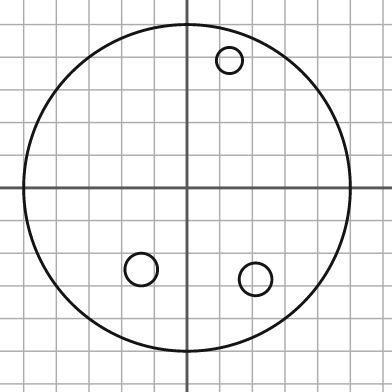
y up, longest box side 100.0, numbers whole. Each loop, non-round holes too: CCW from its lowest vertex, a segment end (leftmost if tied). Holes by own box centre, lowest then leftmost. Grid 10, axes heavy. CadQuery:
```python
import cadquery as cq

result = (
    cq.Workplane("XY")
    .moveTo(0.0, 0.0)
    .circle(50.0)
    .moveTo(21.0, -28.0)
    .circle(5.0)
    .moveTo(-14.0, -25.0)
    .circle(5.0)
    .moveTo(13.0, 39.0)
    .circle(4.0)
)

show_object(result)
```